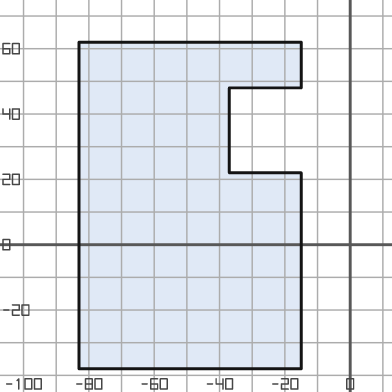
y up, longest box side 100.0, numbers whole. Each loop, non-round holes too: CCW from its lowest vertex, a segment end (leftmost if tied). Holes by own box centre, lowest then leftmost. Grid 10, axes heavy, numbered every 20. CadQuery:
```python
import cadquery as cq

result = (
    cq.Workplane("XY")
    .moveTo(-83.0, -38.0)
    .lineTo(-15.0, -38.0)
    .lineTo(-15.0, 22.0)
    .lineTo(-37.0, 22.0)
    .lineTo(-37.0, 48.0)
    .lineTo(-15.0, 48.0)
    .lineTo(-15.0, 62.0)
    .lineTo(-83.0, 62.0)
    .close()
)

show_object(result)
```